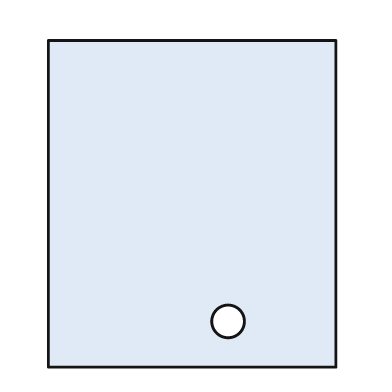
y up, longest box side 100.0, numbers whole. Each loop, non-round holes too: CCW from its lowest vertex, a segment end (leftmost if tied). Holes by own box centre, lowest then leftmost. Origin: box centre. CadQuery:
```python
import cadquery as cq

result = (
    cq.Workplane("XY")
    .moveTo(-44.0, -50.0)
    .lineTo(44.0, -50.0)
    .lineTo(44.0, 50.0)
    .lineTo(-44.0, 50.0)
    .close()
    .moveTo(11.0, -36.0)
    .circle(5.0)
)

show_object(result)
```